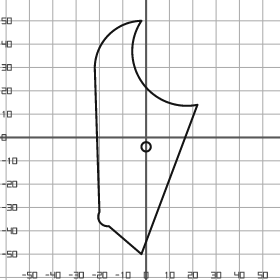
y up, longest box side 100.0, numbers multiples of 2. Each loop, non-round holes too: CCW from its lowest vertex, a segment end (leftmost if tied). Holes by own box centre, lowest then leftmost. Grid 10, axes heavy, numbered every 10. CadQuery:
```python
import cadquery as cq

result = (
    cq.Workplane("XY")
    .moveTo(-2.0, -50.0)
    .lineTo(22.0, 14.0)
    .threePointArc((-2.0, 24.0), (-2.0, 50.0))
    .threePointArc((-16.0, 44.0), (-22.0, 30.0))
    .lineTo(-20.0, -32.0)
    .threePointArc((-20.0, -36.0), (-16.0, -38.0))
    .close()
    .moveTo(0.0, -4.0)
    .circle(2.0)
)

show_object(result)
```